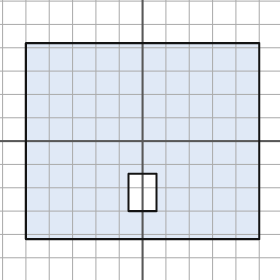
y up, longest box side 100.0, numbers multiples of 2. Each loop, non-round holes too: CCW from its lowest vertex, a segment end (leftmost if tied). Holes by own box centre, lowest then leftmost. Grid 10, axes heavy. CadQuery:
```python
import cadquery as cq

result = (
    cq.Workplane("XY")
    .moveTo(-50.0, -42.0)
    .lineTo(50.0, -42.0)
    .lineTo(50.0, 42.0)
    .lineTo(-50.0, 42.0)
    .close()
    .moveTo(-6.0, -30.0)
    .lineTo(6.0, -30.0)
    .lineTo(6.0, -14.0)
    .lineTo(-6.0, -14.0)
    .close()
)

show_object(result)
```